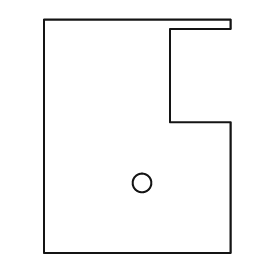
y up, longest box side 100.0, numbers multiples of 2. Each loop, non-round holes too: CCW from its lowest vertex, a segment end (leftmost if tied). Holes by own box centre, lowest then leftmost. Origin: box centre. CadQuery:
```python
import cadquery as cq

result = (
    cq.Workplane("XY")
    .moveTo(-40.0, -50.0)
    .lineTo(40.0, -50.0)
    .lineTo(40.0, 6.0)
    .lineTo(14.0, 6.0)
    .lineTo(14.0, 46.0)
    .lineTo(40.0, 46.0)
    .lineTo(40.0, 50.0)
    .lineTo(-40.0, 50.0)
    .close()
    .moveTo(2.0, -20.0)
    .circle(4.0)
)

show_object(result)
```